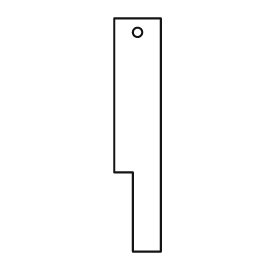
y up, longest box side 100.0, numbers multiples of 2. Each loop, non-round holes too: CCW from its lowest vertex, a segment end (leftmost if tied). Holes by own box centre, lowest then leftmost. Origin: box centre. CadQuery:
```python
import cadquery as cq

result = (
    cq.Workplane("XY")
    .moveTo(-2.0, -50.0)
    .lineTo(10.0, -50.0)
    .lineTo(10.0, 50.0)
    .lineTo(-10.0, 50.0)
    .lineTo(-10.0, -16.0)
    .lineTo(-2.0, -16.0)
    .close()
    .moveTo(0.0, 44.0)
    .circle(2.0)
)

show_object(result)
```